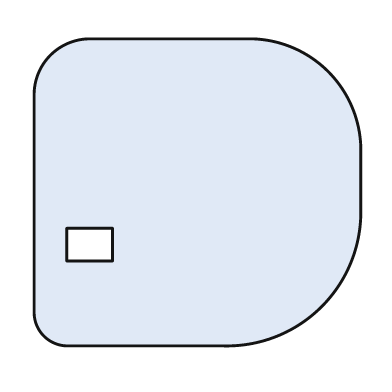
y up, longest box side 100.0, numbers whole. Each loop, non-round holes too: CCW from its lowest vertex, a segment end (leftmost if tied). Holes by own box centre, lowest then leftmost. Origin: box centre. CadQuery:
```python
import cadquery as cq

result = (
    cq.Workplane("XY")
    .moveTo(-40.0, -47.0)
    .lineTo(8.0, -47.0)
    .threePointArc((38.0, -35.0), (50.0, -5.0))
    .lineTo(50.0, 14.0)
    .threePointArc((40.0, 37.0), (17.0, 47.0))
    .lineTo(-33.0, 47.0)
    .threePointArc((-45.0, 42.0), (-50.0, 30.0))
    .lineTo(-50.0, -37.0)
    .threePointArc((-47.0, -44.0), (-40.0, -47.0))
    .close()
    .moveTo(-40.0, -21.0)
    .lineTo(-26.0, -21.0)
    .lineTo(-26.0, -11.0)
    .lineTo(-40.0, -11.0)
    .close()
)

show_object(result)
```